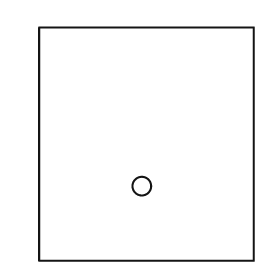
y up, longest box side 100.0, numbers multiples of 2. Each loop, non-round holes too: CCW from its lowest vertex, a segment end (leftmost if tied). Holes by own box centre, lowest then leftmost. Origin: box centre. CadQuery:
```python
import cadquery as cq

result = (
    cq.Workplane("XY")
    .moveTo(-46.0, -50.0)
    .lineTo(46.0, -50.0)
    .lineTo(46.0, 50.0)
    .lineTo(-46.0, 50.0)
    .close()
    .moveTo(-2.0, -18.0)
    .circle(4.0)
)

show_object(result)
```